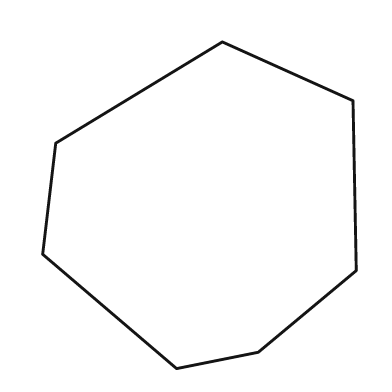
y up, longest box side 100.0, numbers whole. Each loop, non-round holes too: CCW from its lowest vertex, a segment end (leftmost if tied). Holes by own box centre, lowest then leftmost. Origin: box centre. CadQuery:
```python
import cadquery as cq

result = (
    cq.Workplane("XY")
    .moveTo(-7.0, -50.0)
    .lineTo(18.0, -45.0)
    .lineTo(48.0, -20.0)
    .lineTo(47.0, 32.0)
    .lineTo(7.0, 50.0)
    .lineTo(-44.0, 19.0)
    .lineTo(-48.0, -15.0)
    .close()
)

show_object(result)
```